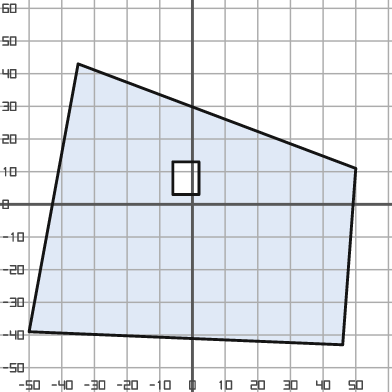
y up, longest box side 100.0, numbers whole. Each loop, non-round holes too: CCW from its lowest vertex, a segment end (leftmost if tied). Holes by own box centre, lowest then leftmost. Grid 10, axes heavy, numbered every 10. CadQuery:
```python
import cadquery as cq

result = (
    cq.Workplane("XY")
    .moveTo(46.0, -43.0)
    .lineTo(50.0, 11.0)
    .lineTo(-35.0, 43.0)
    .lineTo(-50.0, -39.0)
    .close()
    .moveTo(-6.0, 3.0)
    .lineTo(2.0, 3.0)
    .lineTo(2.0, 13.0)
    .lineTo(-6.0, 13.0)
    .close()
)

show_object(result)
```